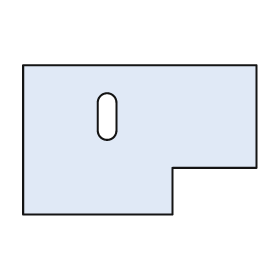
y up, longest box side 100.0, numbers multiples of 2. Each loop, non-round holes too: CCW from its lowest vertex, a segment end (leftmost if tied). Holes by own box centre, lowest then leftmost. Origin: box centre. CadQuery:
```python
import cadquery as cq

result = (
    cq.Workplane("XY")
    .moveTo(-50.0, -32.0)
    .lineTo(14.0, -32.0)
    .lineTo(14.0, -12.0)
    .lineTo(50.0, -12.0)
    .lineTo(50.0, 32.0)
    .lineTo(-50.0, 32.0)
    .close()
    .moveTo(-18.0, 4.0)
    .threePointArc((-14.0, 0.0), (-10.0, 4.0))
    .lineTo(-10.0, 16.0)
    .threePointArc((-14.0, 20.0), (-18.0, 16.0))
    .close()
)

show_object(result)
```